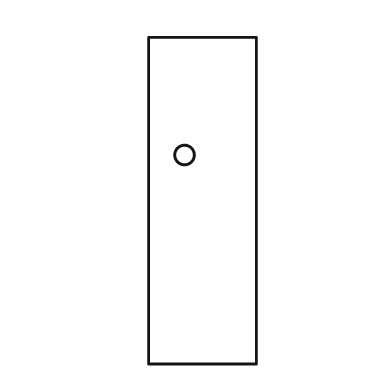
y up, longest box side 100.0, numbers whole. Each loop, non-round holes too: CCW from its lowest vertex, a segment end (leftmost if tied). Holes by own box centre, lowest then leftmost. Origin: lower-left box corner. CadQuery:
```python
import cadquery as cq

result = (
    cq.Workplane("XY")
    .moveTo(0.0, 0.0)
    .lineTo(33.0, 0.0)
    .lineTo(33.0, 100.0)
    .lineTo(0.0, 100.0)
    .close()
    .moveTo(11.0, 64.0)
    .circle(3.0)
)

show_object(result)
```